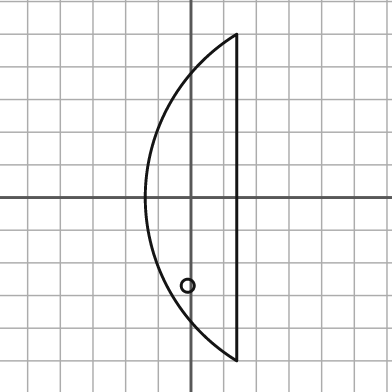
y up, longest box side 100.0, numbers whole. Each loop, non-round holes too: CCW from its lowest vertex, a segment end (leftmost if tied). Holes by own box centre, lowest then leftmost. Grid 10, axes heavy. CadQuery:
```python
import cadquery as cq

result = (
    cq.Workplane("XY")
    .moveTo(14.0, -50.0)
    .lineTo(14.0, 50.0)
    .threePointArc((-14.0, 0.0), (14.0, -50.0))
    .close()
    .moveTo(-1.0, -27.0)
    .circle(2.0)
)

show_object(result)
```